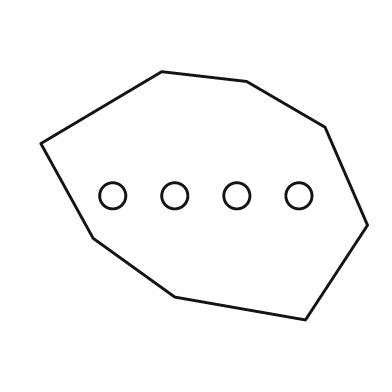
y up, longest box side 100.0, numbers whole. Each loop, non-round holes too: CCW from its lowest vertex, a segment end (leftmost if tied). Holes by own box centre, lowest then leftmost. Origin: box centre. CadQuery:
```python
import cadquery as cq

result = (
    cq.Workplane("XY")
    .moveTo(31.0, -38.0)
    .lineTo(50.0, -9.0)
    .lineTo(37.0, 21.0)
    .lineTo(13.0, 35.0)
    .lineTo(-13.0, 38.0)
    .lineTo(-50.0, 16.0)
    .lineTo(-34.0, -13.0)
    .lineTo(-9.0, -31.0)
    .close()
    .moveTo(-28.0, 0.0)
    .circle(4.0)
    .moveTo(-9.0, 0.0)
    .circle(4.0)
    .moveTo(10.0, 0.0)
    .circle(4.0)
    .moveTo(29.0, 0.0)
    .circle(4.0)
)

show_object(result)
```